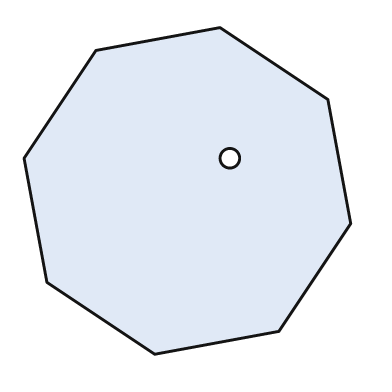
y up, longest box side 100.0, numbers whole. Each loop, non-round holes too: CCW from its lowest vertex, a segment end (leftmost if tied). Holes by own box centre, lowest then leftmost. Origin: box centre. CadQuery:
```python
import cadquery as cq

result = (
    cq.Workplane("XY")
    .moveTo(-10.0, -50.0)
    .lineTo(28.0, -43.0)
    .lineTo(50.0, -10.0)
    .lineTo(43.0, 28.0)
    .lineTo(10.0, 50.0)
    .lineTo(-28.0, 43.0)
    .lineTo(-50.0, 10.0)
    .lineTo(-43.0, -28.0)
    .close()
    .moveTo(13.0, 10.0)
    .circle(3.0)
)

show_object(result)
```